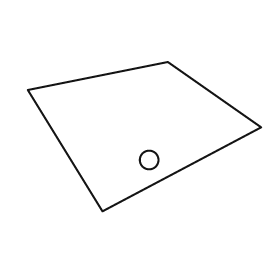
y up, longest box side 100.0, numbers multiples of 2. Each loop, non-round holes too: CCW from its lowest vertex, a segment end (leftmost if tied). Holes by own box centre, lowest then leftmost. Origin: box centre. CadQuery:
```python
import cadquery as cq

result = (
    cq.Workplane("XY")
    .moveTo(-18.0, -32.0)
    .lineTo(50.0, 4.0)
    .lineTo(10.0, 32.0)
    .lineTo(-50.0, 20.0)
    .close()
    .moveTo(2.0, -10.0)
    .circle(4.0)
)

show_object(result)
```